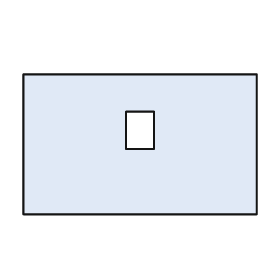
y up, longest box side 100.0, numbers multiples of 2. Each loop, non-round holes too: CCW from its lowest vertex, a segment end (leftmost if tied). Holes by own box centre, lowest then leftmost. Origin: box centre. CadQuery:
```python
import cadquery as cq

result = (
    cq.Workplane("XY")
    .moveTo(-50.0, -30.0)
    .lineTo(50.0, -30.0)
    .lineTo(50.0, 30.0)
    .lineTo(-50.0, 30.0)
    .close()
    .moveTo(-6.0, -2.0)
    .lineTo(6.0, -2.0)
    .lineTo(6.0, 14.0)
    .lineTo(-6.0, 14.0)
    .close()
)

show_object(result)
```